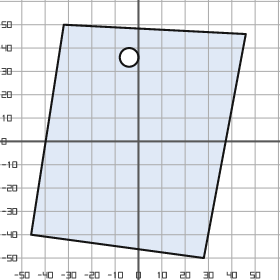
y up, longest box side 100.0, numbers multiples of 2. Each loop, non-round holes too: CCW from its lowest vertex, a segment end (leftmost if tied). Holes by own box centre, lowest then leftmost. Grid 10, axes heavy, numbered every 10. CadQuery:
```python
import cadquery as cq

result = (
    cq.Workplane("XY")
    .moveTo(28.0, -50.0)
    .lineTo(46.0, 46.0)
    .lineTo(-32.0, 50.0)
    .lineTo(-46.0, -40.0)
    .close()
    .moveTo(-4.0, 36.0)
    .circle(4.0)
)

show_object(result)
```